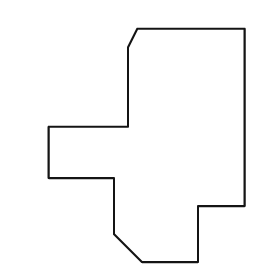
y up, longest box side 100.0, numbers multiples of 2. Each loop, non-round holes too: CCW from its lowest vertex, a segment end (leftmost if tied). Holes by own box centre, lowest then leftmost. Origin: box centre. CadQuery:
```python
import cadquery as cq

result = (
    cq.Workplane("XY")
    .moveTo(-2.0, -50.0)
    .lineTo(22.0, -50.0)
    .lineTo(22.0, -26.0)
    .lineTo(42.0, -26.0)
    .lineTo(42.0, 50.0)
    .lineTo(-4.0, 50.0)
    .lineTo(-8.0, 42.0)
    .lineTo(-8.0, 8.0)
    .lineTo(-42.0, 8.0)
    .lineTo(-42.0, -14.0)
    .lineTo(-14.0, -14.0)
    .lineTo(-14.0, -38.0)
    .close()
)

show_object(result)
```